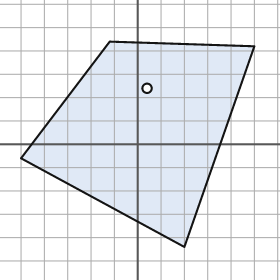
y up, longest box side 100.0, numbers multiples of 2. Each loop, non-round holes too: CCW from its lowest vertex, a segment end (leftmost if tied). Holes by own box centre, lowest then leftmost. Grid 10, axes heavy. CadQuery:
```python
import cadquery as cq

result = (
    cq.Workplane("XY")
    .moveTo(20.0, -44.0)
    .lineTo(50.0, 42.0)
    .lineTo(-12.0, 44.0)
    .lineTo(-50.0, -6.0)
    .close()
    .moveTo(4.0, 24.0)
    .circle(2.0)
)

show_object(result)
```